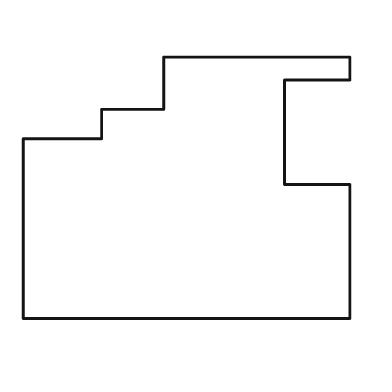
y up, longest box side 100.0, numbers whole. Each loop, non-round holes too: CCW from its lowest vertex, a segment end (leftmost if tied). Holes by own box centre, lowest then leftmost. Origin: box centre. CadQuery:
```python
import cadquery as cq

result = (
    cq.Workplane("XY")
    .moveTo(-50.0, -40.0)
    .lineTo(50.0, -40.0)
    .lineTo(50.0, 1.0)
    .lineTo(30.0, 1.0)
    .lineTo(30.0, 33.0)
    .lineTo(50.0, 33.0)
    .lineTo(50.0, 40.0)
    .lineTo(-7.0, 40.0)
    .lineTo(-7.0, 24.0)
    .lineTo(-26.0, 24.0)
    .lineTo(-26.0, 15.0)
    .lineTo(-50.0, 15.0)
    .close()
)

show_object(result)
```